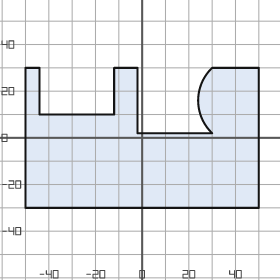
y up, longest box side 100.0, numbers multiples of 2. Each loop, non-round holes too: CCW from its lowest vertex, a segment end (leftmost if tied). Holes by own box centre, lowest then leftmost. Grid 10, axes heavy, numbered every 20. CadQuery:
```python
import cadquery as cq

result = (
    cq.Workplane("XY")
    .moveTo(-50.0, -30.0)
    .lineTo(50.0, -30.0)
    .lineTo(50.0, 30.0)
    .lineTo(30.0, 30.0)
    .threePointArc((24.0, 16.0), (30.0, 2.0))
    .lineTo(-2.0, 2.0)
    .lineTo(-2.0, 30.0)
    .lineTo(-12.0, 30.0)
    .lineTo(-12.0, 10.0)
    .lineTo(-44.0, 10.0)
    .lineTo(-44.0, 30.0)
    .lineTo(-50.0, 30.0)
    .close()
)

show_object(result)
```